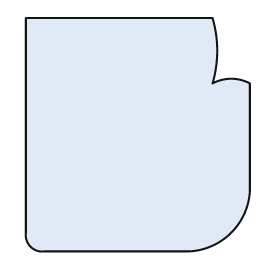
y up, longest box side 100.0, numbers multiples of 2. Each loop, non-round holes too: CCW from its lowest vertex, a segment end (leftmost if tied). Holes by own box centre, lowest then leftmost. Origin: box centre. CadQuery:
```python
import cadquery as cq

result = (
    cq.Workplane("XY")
    .moveTo(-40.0, -50.0)
    .lineTo(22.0, -50.0)
    .threePointArc((40.0, -42.0), (48.0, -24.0))
    .lineTo(48.0, 22.0)
    .threePointArc((40.0, 24.0), (32.0, 22.0))
    .threePointArc((34.0, 36.0), (32.0, 50.0))
    .lineTo(-48.0, 50.0)
    .lineTo(-48.0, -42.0)
    .threePointArc((-46.0, -48.0), (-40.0, -50.0))
    .close()
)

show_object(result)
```